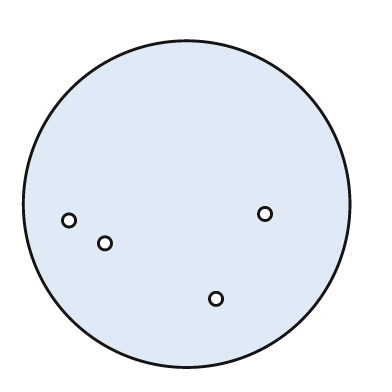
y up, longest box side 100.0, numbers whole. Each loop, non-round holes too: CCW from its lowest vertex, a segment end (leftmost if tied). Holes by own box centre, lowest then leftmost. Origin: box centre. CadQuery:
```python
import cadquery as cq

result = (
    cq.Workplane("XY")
    .moveTo(0.0, 0.0)
    .circle(50.0)
    .moveTo(9.0, -29.0)
    .circle(2.0)
    .moveTo(-25.0, -12.0)
    .circle(2.0)
    .moveTo(-36.0, -5.0)
    .circle(2.0)
    .moveTo(24.0, -3.0)
    .circle(2.0)
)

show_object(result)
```